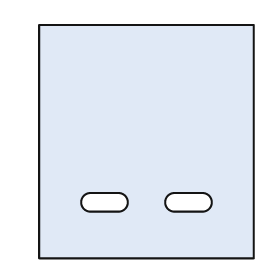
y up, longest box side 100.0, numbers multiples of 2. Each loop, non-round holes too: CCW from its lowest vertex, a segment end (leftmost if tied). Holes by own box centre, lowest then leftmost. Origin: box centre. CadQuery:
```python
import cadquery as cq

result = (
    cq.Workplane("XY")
    .moveTo(-46.0, -50.0)
    .lineTo(46.0, -50.0)
    .lineTo(46.0, 50.0)
    .lineTo(-46.0, 50.0)
    .close()
    .moveTo(-24.0, -30.0)
    .lineTo(-12.0, -30.0)
    .threePointArc((-8.0, -26.0), (-12.0, -22.0))
    .lineTo(-24.0, -22.0)
    .threePointArc((-28.0, -26.0), (-24.0, -30.0))
    .close()
    .moveTo(12.0, -30.0)
    .lineTo(24.0, -30.0)
    .threePointArc((28.0, -26.0), (24.0, -22.0))
    .lineTo(12.0, -22.0)
    .threePointArc((8.0, -26.0), (12.0, -30.0))
    .close()
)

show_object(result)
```